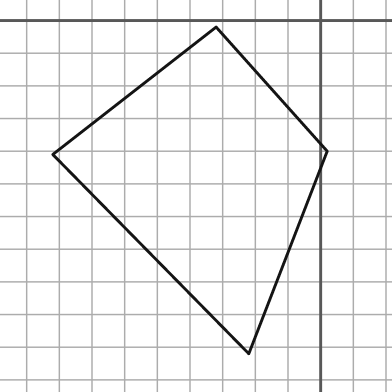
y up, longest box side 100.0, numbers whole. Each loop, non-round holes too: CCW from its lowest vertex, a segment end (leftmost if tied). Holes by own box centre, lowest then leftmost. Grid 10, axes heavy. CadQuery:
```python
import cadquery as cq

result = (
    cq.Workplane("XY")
    .moveTo(-22.0, -102.0)
    .lineTo(2.0, -40.0)
    .lineTo(-32.0, -2.0)
    .lineTo(-82.0, -41.0)
    .close()
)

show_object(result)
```